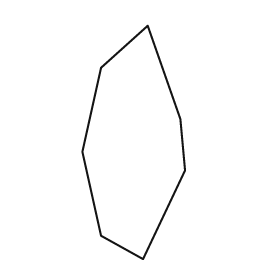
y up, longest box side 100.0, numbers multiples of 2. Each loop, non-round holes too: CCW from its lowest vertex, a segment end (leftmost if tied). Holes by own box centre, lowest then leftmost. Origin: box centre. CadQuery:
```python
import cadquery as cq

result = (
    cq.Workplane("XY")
    .moveTo(4.0, -50.0)
    .lineTo(22.0, -12.0)
    .lineTo(20.0, 10.0)
    .lineTo(6.0, 50.0)
    .lineTo(-14.0, 32.0)
    .lineTo(-22.0, -4.0)
    .lineTo(-14.0, -40.0)
    .close()
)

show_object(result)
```